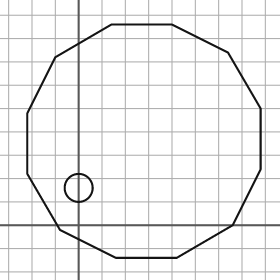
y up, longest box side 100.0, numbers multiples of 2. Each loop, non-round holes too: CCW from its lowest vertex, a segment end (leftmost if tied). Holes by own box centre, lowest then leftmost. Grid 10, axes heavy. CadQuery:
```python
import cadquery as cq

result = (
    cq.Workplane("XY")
    .moveTo(16.0, -14.0)
    .lineTo(42.0, -14.0)
    .lineTo(66.0, 0.0)
    .lineTo(78.0, 24.0)
    .lineTo(78.0, 50.0)
    .lineTo(64.0, 74.0)
    .lineTo(40.0, 86.0)
    .lineTo(14.0, 86.0)
    .lineTo(-10.0, 72.0)
    .lineTo(-22.0, 48.0)
    .lineTo(-22.0, 22.0)
    .lineTo(-8.0, -2.0)
    .close()
    .moveTo(0.0, 16.0)
    .circle(6.0)
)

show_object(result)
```